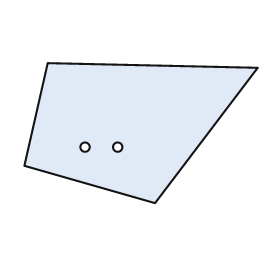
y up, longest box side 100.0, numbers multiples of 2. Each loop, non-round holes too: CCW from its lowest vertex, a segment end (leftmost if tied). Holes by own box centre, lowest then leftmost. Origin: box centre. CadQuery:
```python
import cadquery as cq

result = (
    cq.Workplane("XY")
    .moveTo(6.0, -30.0)
    .lineTo(50.0, 28.0)
    .lineTo(-40.0, 30.0)
    .lineTo(-50.0, -14.0)
    .close()
    .moveTo(-24.0, -6.0)
    .circle(2.0)
    .moveTo(-10.0, -6.0)
    .circle(2.0)
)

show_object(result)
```